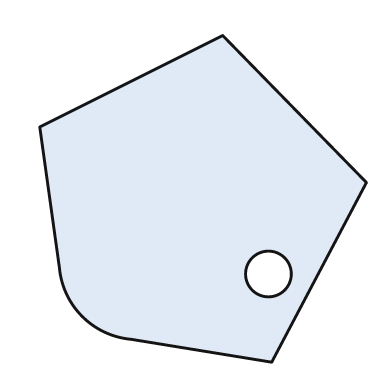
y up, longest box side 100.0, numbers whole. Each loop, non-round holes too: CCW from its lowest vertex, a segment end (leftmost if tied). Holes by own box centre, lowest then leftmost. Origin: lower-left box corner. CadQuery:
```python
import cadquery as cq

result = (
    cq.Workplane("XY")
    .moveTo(71.0, 0.0)
    .lineTo(100.0, 55.0)
    .lineTo(56.0, 100.0)
    .lineTo(0.0, 72.0)
    .lineTo(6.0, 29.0)
    .threePointArc((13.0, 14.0), (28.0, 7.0))
    .close()
    .moveTo(70.0, 27.0)
    .circle(7.0)
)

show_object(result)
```